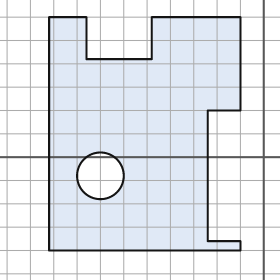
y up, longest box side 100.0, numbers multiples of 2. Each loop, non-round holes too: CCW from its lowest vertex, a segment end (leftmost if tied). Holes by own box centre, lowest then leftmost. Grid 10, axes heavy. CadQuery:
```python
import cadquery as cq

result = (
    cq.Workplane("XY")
    .moveTo(-92.0, -40.0)
    .lineTo(-10.0, -40.0)
    .lineTo(-10.0, -36.0)
    .lineTo(-24.0, -36.0)
    .lineTo(-24.0, 20.0)
    .lineTo(-10.0, 20.0)
    .lineTo(-10.0, 60.0)
    .lineTo(-48.0, 60.0)
    .lineTo(-48.0, 42.0)
    .lineTo(-76.0, 42.0)
    .lineTo(-76.0, 60.0)
    .lineTo(-92.0, 60.0)
    .close()
    .moveTo(-70.0, -8.0)
    .circle(10.0)
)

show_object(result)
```